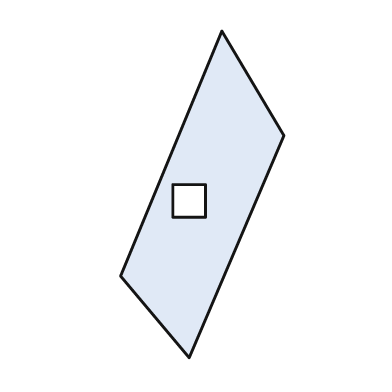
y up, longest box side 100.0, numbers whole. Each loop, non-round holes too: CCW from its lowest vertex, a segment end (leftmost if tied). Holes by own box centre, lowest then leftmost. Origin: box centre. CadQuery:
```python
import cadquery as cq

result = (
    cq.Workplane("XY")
    .moveTo(-4.0, -50.0)
    .lineTo(25.0, 18.0)
    .lineTo(6.0, 50.0)
    .lineTo(-25.0, -25.0)
    .close()
    .moveTo(-9.0, -7.0)
    .lineTo(1.0, -7.0)
    .lineTo(1.0, 3.0)
    .lineTo(-9.0, 3.0)
    .close()
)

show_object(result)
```